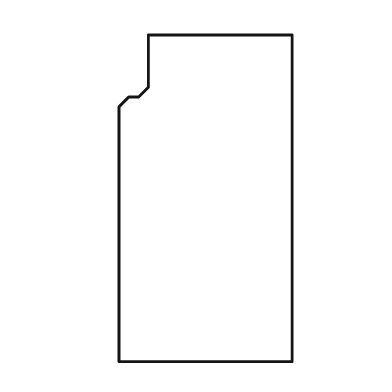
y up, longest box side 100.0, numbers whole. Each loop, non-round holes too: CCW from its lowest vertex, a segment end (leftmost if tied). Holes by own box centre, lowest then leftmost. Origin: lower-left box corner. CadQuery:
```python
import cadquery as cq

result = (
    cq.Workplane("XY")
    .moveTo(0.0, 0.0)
    .lineTo(53.0, 0.0)
    .lineTo(53.0, 100.0)
    .lineTo(9.0, 100.0)
    .lineTo(9.0, 84.0)
    .lineTo(6.0, 81.0)
    .lineTo(3.0, 81.0)
    .lineTo(0.0, 78.0)
    .close()
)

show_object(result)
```